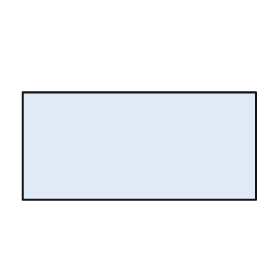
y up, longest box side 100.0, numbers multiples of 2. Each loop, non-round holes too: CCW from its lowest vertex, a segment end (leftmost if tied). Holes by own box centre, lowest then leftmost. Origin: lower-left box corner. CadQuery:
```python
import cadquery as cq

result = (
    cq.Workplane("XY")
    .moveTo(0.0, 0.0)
    .lineTo(100.0, 0.0)
    .lineTo(100.0, 46.0)
    .lineTo(0.0, 46.0)
    .close()
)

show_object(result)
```